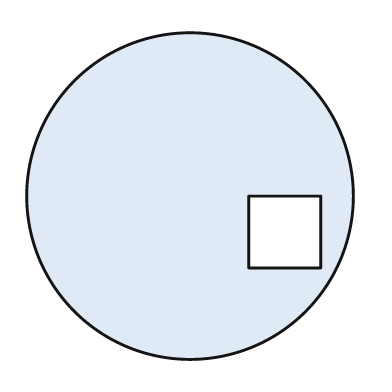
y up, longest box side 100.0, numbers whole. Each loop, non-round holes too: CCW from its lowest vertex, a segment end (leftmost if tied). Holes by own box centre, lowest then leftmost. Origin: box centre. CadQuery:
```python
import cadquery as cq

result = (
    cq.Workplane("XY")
    .moveTo(0.0, 0.0)
    .circle(50.0)
    .moveTo(18.0, -22.0)
    .lineTo(40.0, -22.0)
    .lineTo(40.0, 0.0)
    .lineTo(18.0, 0.0)
    .close()
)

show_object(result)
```